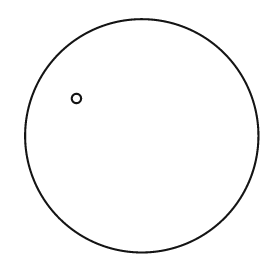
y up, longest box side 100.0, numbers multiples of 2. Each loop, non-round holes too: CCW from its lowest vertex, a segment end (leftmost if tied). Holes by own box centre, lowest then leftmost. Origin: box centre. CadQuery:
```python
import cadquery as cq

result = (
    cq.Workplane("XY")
    .moveTo(0.0, 0.0)
    .circle(50.0)
    .moveTo(-28.0, 16.0)
    .circle(2.0)
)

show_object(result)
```